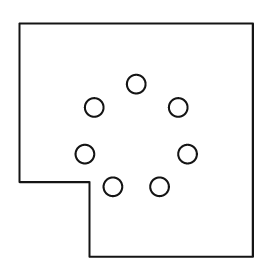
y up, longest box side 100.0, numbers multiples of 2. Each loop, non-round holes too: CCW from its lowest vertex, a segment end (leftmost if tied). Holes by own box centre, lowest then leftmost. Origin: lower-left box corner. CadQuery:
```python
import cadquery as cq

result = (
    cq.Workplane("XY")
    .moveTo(30.0, 0.0)
    .lineTo(100.0, 0.0)
    .lineTo(100.0, 100.0)
    .lineTo(0.0, 100.0)
    .lineTo(0.0, 32.0)
    .lineTo(30.0, 32.0)
    .close()
    .moveTo(40.0, 30.0)
    .circle(4.0)
    .moveTo(60.0, 30.0)
    .circle(4.0)
    .moveTo(28.0, 44.0)
    .circle(4.0)
    .moveTo(72.0, 44.0)
    .circle(4.0)
    .moveTo(32.0, 64.0)
    .circle(4.0)
    .moveTo(68.0, 64.0)
    .circle(4.0)
    .moveTo(50.0, 74.0)
    .circle(4.0)
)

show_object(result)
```